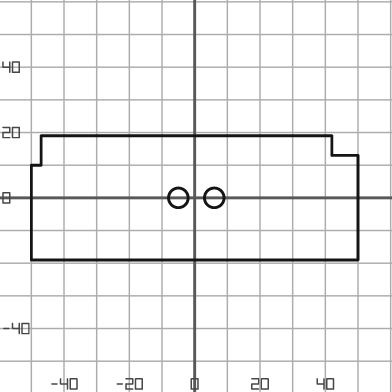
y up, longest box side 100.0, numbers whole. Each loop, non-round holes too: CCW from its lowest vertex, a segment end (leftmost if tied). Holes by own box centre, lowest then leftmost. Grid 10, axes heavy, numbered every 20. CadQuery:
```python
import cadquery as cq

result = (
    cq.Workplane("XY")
    .moveTo(-50.0, -19.0)
    .lineTo(50.0, -19.0)
    .lineTo(50.0, 13.0)
    .lineTo(42.0, 13.0)
    .lineTo(42.0, 19.0)
    .lineTo(-47.0, 19.0)
    .lineTo(-47.0, 10.0)
    .lineTo(-50.0, 10.0)
    .close()
    .moveTo(-5.0, 0.0)
    .circle(3.0)
    .moveTo(6.0, 0.0)
    .circle(3.0)
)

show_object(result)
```